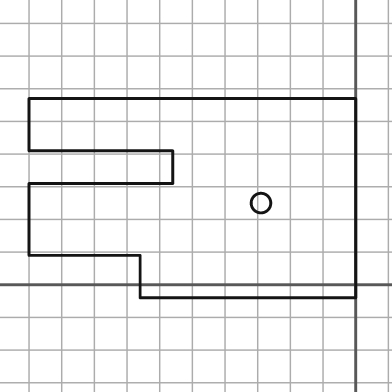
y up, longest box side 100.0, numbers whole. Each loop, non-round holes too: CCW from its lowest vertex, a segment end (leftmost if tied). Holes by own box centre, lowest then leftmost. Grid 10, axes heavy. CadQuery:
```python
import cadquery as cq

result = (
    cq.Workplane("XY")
    .moveTo(-66.0, -4.0)
    .lineTo(0.0, -4.0)
    .lineTo(0.0, 57.0)
    .lineTo(-100.0, 57.0)
    .lineTo(-100.0, 41.0)
    .lineTo(-56.0, 41.0)
    .lineTo(-56.0, 31.0)
    .lineTo(-100.0, 31.0)
    .lineTo(-100.0, 9.0)
    .lineTo(-66.0, 9.0)
    .close()
    .moveTo(-29.0, 25.0)
    .circle(3.0)
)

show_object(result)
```